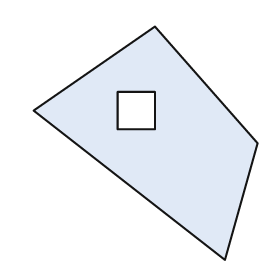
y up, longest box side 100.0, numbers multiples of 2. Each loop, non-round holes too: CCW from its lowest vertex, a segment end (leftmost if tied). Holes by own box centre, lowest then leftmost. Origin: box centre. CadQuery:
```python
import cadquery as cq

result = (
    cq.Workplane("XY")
    .moveTo(34.0, -50.0)
    .lineTo(48.0, 0.0)
    .lineTo(4.0, 50.0)
    .lineTo(-48.0, 14.0)
    .close()
    .moveTo(-12.0, 6.0)
    .lineTo(4.0, 6.0)
    .lineTo(4.0, 22.0)
    .lineTo(-12.0, 22.0)
    .close()
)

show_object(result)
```